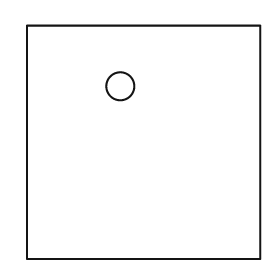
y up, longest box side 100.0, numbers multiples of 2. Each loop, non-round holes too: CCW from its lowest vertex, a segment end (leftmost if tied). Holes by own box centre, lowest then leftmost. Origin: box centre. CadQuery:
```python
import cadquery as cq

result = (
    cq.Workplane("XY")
    .moveTo(-50.0, -50.0)
    .lineTo(50.0, -50.0)
    .lineTo(50.0, 50.0)
    .lineTo(-50.0, 50.0)
    .close()
    .moveTo(-10.0, 24.0)
    .circle(6.0)
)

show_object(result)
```